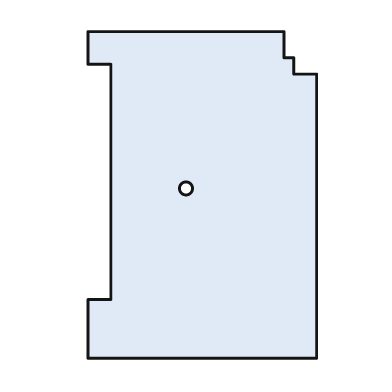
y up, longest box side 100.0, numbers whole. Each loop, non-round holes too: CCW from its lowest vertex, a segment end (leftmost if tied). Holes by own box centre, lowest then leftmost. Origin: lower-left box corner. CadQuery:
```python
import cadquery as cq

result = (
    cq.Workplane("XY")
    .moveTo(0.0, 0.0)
    .lineTo(70.0, 0.0)
    .lineTo(70.0, 87.0)
    .lineTo(63.0, 87.0)
    .lineTo(63.0, 92.0)
    .lineTo(60.0, 92.0)
    .lineTo(60.0, 100.0)
    .lineTo(0.0, 100.0)
    .lineTo(0.0, 90.0)
    .lineTo(7.0, 90.0)
    .lineTo(7.0, 18.0)
    .lineTo(0.0, 18.0)
    .close()
    .moveTo(30.0, 52.0)
    .circle(2.0)
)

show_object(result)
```